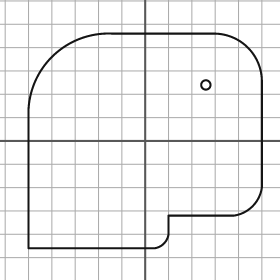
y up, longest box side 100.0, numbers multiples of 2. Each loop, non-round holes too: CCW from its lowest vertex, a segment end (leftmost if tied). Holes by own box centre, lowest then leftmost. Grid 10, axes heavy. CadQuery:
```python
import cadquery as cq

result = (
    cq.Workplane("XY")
    .moveTo(-50.0, -46.0)
    .lineTo(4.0, -46.0)
    .threePointArc((8.0, -44.0), (10.0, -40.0))
    .lineTo(10.0, -32.0)
    .lineTo(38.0, -32.0)
    .threePointArc((46.0, -28.0), (50.0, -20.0))
    .lineTo(50.0, 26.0)
    .threePointArc((44.0, 40.0), (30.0, 46.0))
    .lineTo(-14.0, 46.0)
    .threePointArc((-40.0, 36.0), (-50.0, 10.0))
    .close()
    .moveTo(26.0, 24.0)
    .circle(2.0)
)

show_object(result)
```